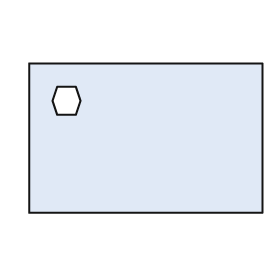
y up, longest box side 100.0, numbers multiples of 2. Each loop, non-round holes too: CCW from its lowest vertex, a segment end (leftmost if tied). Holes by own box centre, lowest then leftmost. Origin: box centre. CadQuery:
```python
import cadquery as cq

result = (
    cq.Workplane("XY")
    .moveTo(-50.0, -32.0)
    .lineTo(50.0, -32.0)
    .lineTo(50.0, 32.0)
    .lineTo(-50.0, 32.0)
    .close()
    .moveTo(-38.0, 10.0)
    .lineTo(-30.0, 10.0)
    .lineTo(-28.0, 16.0)
    .lineTo(-30.0, 22.0)
    .lineTo(-38.0, 22.0)
    .lineTo(-40.0, 16.0)
    .close()
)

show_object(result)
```